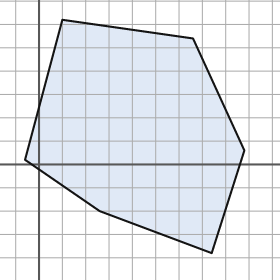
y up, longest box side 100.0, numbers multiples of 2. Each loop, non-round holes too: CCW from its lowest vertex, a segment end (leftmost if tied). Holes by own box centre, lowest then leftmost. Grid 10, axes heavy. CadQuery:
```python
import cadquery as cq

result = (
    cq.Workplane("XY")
    .moveTo(74.0, -38.0)
    .lineTo(88.0, 6.0)
    .lineTo(66.0, 54.0)
    .lineTo(10.0, 62.0)
    .lineTo(-6.0, 2.0)
    .lineTo(26.0, -20.0)
    .close()
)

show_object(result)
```